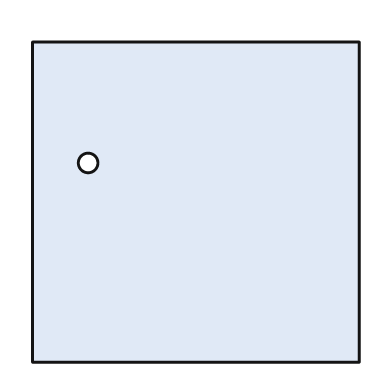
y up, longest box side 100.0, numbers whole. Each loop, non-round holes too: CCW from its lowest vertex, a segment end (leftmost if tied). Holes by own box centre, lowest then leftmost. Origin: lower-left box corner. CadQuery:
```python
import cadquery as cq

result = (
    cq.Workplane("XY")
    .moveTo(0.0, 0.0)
    .lineTo(100.0, 0.0)
    .lineTo(100.0, 98.0)
    .lineTo(0.0, 98.0)
    .close()
    .moveTo(17.0, 61.0)
    .circle(3.0)
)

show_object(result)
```